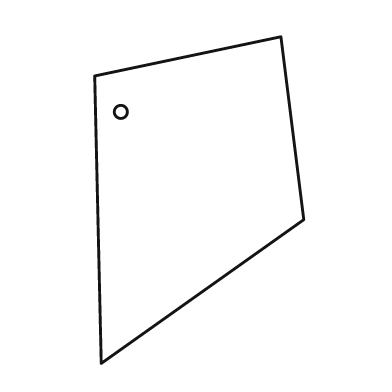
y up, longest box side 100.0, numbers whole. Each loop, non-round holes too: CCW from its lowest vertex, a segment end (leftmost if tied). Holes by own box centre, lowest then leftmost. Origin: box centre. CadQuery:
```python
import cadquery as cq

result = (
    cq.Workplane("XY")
    .moveTo(-30.0, -50.0)
    .lineTo(32.0, -6.0)
    .lineTo(25.0, 50.0)
    .lineTo(-32.0, 38.0)
    .close()
    .moveTo(-24.0, 27.0)
    .circle(2.0)
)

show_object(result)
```